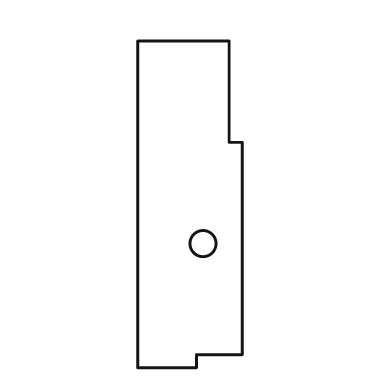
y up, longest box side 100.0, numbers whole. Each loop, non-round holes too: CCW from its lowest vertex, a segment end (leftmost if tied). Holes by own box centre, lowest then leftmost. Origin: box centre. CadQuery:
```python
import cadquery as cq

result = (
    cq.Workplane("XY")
    .moveTo(-16.0, -50.0)
    .lineTo(2.0, -50.0)
    .lineTo(2.0, -46.0)
    .lineTo(16.0, -46.0)
    .lineTo(16.0, 19.0)
    .lineTo(12.0, 19.0)
    .lineTo(12.0, 50.0)
    .lineTo(-16.0, 50.0)
    .close()
    .moveTo(4.0, -12.0)
    .circle(4.0)
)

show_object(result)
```